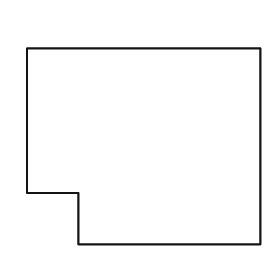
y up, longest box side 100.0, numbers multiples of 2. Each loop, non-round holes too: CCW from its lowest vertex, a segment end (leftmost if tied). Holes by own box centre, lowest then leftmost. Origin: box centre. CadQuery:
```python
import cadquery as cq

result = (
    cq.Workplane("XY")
    .moveTo(-28.0, -42.0)
    .lineTo(50.0, -42.0)
    .lineTo(50.0, 42.0)
    .lineTo(-50.0, 42.0)
    .lineTo(-50.0, -20.0)
    .lineTo(-28.0, -20.0)
    .close()
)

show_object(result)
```